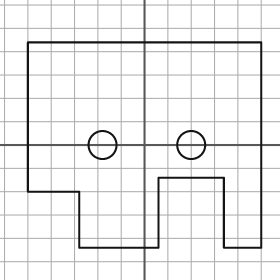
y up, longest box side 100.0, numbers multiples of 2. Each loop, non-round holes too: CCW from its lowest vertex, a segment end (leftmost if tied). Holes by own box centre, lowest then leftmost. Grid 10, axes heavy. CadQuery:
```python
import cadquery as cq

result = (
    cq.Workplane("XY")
    .moveTo(-28.0, -44.0)
    .lineTo(6.0, -44.0)
    .lineTo(6.0, -14.0)
    .lineTo(34.0, -14.0)
    .lineTo(34.0, -44.0)
    .lineTo(50.0, -44.0)
    .lineTo(50.0, 44.0)
    .lineTo(-50.0, 44.0)
    .lineTo(-50.0, -20.0)
    .lineTo(-28.0, -20.0)
    .close()
    .moveTo(-18.0, 0.0)
    .circle(6.0)
    .moveTo(20.0, 0.0)
    .circle(6.0)
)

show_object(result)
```